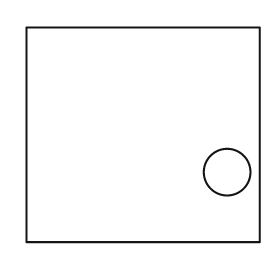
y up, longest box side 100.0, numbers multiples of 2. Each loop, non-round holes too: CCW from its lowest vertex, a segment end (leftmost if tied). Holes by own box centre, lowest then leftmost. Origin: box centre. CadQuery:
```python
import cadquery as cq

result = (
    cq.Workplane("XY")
    .moveTo(-50.0, -46.0)
    .lineTo(50.0, -46.0)
    .lineTo(50.0, 46.0)
    .lineTo(-50.0, 46.0)
    .close()
    .moveTo(36.0, -16.0)
    .circle(10.0)
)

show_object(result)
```